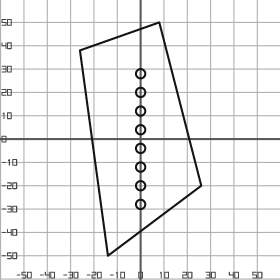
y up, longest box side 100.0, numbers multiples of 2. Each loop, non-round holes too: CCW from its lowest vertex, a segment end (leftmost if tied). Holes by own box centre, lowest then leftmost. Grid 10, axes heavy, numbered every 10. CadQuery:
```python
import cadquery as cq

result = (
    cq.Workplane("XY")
    .moveTo(-14.0, -50.0)
    .lineTo(26.0, -20.0)
    .lineTo(8.0, 50.0)
    .lineTo(-26.0, 38.0)
    .close()
    .moveTo(0.0, -28.0)
    .circle(2.0)
    .moveTo(0.0, -20.0)
    .circle(2.0)
    .moveTo(0.0, -12.0)
    .circle(2.0)
    .moveTo(0.0, -4.0)
    .circle(2.0)
    .moveTo(0.0, 4.0)
    .circle(2.0)
    .moveTo(0.0, 12.0)
    .circle(2.0)
    .moveTo(0.0, 20.0)
    .circle(2.0)
    .moveTo(0.0, 28.0)
    .circle(2.0)
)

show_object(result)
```